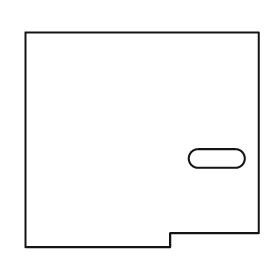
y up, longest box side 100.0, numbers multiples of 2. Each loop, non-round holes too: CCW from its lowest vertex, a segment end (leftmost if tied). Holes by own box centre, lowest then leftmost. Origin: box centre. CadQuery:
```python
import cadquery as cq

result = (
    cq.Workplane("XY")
    .moveTo(-50.0, -46.0)
    .lineTo(12.0, -46.0)
    .lineTo(12.0, -40.0)
    .lineTo(50.0, -40.0)
    .lineTo(50.0, 46.0)
    .lineTo(-50.0, 46.0)
    .close()
    .moveTo(24.0, -12.0)
    .lineTo(40.0, -12.0)
    .threePointArc((44.0, -8.0), (40.0, -4.0))
    .lineTo(24.0, -4.0)
    .threePointArc((20.0, -8.0), (24.0, -12.0))
    .close()
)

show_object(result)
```